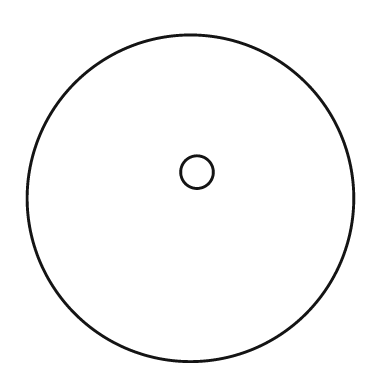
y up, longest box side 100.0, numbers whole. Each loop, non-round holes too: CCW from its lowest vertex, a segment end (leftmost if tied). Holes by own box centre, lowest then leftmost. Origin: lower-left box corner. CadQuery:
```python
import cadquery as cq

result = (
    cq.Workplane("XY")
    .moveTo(50.0, 50.0)
    .circle(50.0)
    .moveTo(52.0, 58.0)
    .circle(5.0)
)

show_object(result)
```